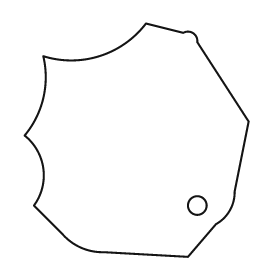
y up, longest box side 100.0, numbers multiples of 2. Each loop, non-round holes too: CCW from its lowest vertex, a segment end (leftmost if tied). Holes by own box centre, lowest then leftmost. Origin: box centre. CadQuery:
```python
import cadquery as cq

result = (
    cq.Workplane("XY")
    .moveTo(22.0, -50.0)
    .lineTo(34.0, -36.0)
    .threePointArc((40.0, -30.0), (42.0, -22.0))
    .lineTo(48.0, 8.0)
    .lineTo(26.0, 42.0)
    .threePointArc((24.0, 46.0), (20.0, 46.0))
    .lineTo(4.0, 50.0)
    .threePointArc((-16.0, 36.0), (-40.0, 36.0))
    .threePointArc((-40.0, 18.0), (-48.0, 2.0))
    .threePointArc((-40.0, -12.0), (-44.0, -28.0))
    .lineTo(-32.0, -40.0)
    .threePointArc((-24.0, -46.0), (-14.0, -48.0))
    .close()
    .moveTo(26.0, -28.0)
    .circle(4.0)
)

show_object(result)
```